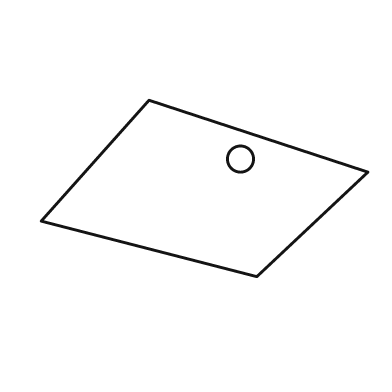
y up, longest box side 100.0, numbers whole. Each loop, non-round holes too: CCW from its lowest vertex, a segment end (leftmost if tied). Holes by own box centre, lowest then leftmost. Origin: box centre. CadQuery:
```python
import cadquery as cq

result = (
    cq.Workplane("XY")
    .moveTo(16.0, -27.0)
    .lineTo(50.0, 5.0)
    .lineTo(-17.0, 27.0)
    .lineTo(-50.0, -10.0)
    .close()
    .moveTo(11.0, 9.0)
    .circle(4.0)
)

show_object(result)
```